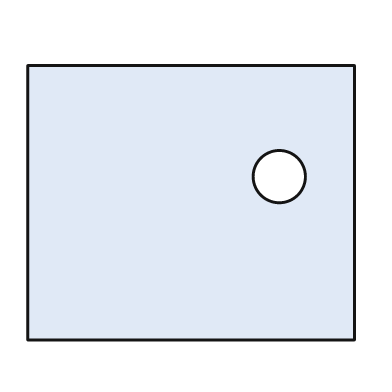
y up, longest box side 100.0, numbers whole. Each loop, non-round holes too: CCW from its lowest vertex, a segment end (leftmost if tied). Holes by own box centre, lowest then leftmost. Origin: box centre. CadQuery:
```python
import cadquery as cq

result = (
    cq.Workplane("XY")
    .moveTo(-50.0, -42.0)
    .lineTo(50.0, -42.0)
    .lineTo(50.0, 42.0)
    .lineTo(-50.0, 42.0)
    .close()
    .moveTo(27.0, 8.0)
    .circle(8.0)
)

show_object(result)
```